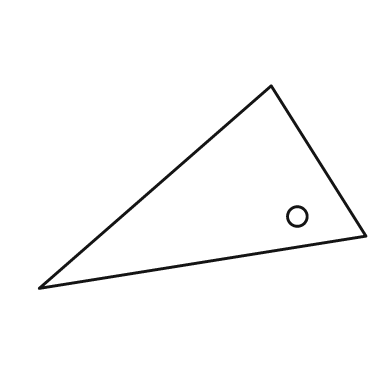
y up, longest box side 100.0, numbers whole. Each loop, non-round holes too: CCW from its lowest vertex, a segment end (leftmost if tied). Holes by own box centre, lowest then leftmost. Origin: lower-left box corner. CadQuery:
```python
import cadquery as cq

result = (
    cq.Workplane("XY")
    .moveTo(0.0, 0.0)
    .lineTo(100.0, 16.0)
    .lineTo(71.0, 62.0)
    .close()
    .moveTo(79.0, 22.0)
    .circle(3.0)
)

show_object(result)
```